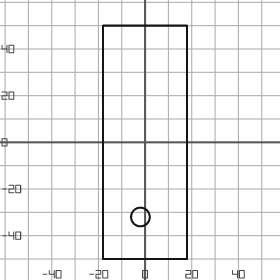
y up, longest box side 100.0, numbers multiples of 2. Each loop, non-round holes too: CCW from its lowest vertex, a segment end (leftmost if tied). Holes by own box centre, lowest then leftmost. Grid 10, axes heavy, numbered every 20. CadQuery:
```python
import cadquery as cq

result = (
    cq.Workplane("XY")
    .moveTo(-18.0, -50.0)
    .lineTo(18.0, -50.0)
    .lineTo(18.0, 50.0)
    .lineTo(-18.0, 50.0)
    .close()
    .moveTo(-2.0, -32.0)
    .circle(4.0)
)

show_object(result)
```